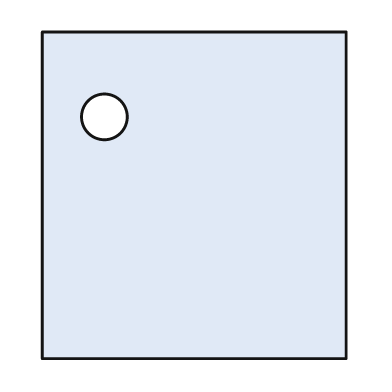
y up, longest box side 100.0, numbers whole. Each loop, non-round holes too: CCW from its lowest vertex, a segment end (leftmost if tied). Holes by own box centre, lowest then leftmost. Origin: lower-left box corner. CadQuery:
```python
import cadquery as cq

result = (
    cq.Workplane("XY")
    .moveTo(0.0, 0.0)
    .lineTo(93.0, 0.0)
    .lineTo(93.0, 100.0)
    .lineTo(0.0, 100.0)
    .close()
    .moveTo(19.0, 74.0)
    .circle(7.0)
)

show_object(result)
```